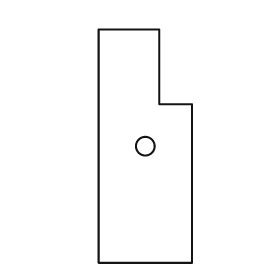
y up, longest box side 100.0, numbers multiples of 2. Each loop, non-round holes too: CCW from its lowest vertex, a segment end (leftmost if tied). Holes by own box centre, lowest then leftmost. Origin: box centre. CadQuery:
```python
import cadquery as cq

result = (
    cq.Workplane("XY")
    .moveTo(-20.0, -50.0)
    .lineTo(20.0, -50.0)
    .lineTo(20.0, 18.0)
    .lineTo(6.0, 18.0)
    .lineTo(6.0, 50.0)
    .lineTo(-20.0, 50.0)
    .close()
    .moveTo(0.0, 0.0)
    .circle(4.0)
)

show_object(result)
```